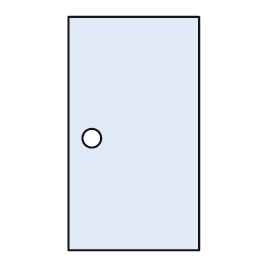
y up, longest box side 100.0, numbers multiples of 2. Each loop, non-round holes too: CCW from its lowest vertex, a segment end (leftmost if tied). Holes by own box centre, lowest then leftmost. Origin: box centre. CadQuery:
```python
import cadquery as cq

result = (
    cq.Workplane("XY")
    .moveTo(-28.0, -50.0)
    .lineTo(28.0, -50.0)
    .lineTo(28.0, 50.0)
    .lineTo(-28.0, 50.0)
    .close()
    .moveTo(-18.0, -2.0)
    .circle(4.0)
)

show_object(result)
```